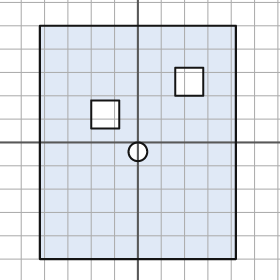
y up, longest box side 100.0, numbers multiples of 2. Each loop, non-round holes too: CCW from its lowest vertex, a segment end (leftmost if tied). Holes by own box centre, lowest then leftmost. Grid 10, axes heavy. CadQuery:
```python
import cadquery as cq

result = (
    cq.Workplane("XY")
    .moveTo(-42.0, -50.0)
    .lineTo(42.0, -50.0)
    .lineTo(42.0, 50.0)
    .lineTo(-42.0, 50.0)
    .close()
    .moveTo(0.0, -4.0)
    .circle(4.0)
    .moveTo(-20.0, 6.0)
    .lineTo(-8.0, 6.0)
    .lineTo(-8.0, 18.0)
    .lineTo(-20.0, 18.0)
    .close()
    .moveTo(16.0, 20.0)
    .lineTo(28.0, 20.0)
    .lineTo(28.0, 32.0)
    .lineTo(16.0, 32.0)
    .close()
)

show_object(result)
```